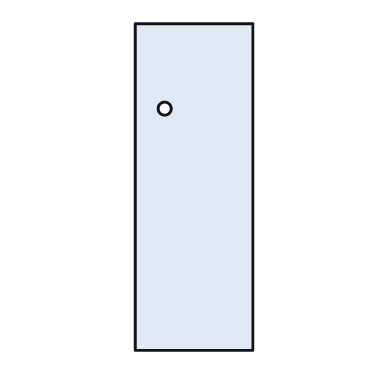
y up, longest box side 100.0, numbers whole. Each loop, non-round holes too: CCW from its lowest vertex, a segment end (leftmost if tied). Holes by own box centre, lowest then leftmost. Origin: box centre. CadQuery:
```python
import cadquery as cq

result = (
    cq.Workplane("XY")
    .moveTo(-18.0, -50.0)
    .lineTo(18.0, -50.0)
    .lineTo(18.0, 50.0)
    .lineTo(-18.0, 50.0)
    .close()
    .moveTo(-9.0, 24.0)
    .circle(2.0)
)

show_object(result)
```